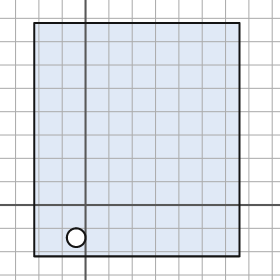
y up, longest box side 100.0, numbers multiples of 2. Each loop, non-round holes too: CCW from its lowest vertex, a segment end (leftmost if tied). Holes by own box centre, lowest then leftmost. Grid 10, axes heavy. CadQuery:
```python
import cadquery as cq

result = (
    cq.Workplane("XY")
    .moveTo(-22.0, -22.0)
    .lineTo(66.0, -22.0)
    .lineTo(66.0, 78.0)
    .lineTo(-22.0, 78.0)
    .close()
    .moveTo(-4.0, -14.0)
    .circle(4.0)
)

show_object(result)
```